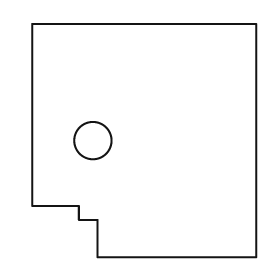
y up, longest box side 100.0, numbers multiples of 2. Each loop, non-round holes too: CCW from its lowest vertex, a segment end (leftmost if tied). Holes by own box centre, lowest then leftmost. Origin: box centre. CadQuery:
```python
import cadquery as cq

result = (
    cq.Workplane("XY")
    .moveTo(-20.0, -50.0)
    .lineTo(48.0, -50.0)
    .lineTo(48.0, 50.0)
    .lineTo(-48.0, 50.0)
    .lineTo(-48.0, -28.0)
    .lineTo(-28.0, -28.0)
    .lineTo(-28.0, -34.0)
    .lineTo(-20.0, -34.0)
    .close()
    .moveTo(-22.0, 0.0)
    .circle(8.0)
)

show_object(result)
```